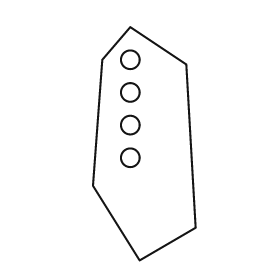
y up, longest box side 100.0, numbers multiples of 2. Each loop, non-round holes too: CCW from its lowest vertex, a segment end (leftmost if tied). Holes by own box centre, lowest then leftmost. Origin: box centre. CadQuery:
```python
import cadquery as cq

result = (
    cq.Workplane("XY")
    .moveTo(-2.0, -50.0)
    .lineTo(22.0, -36.0)
    .lineTo(18.0, 34.0)
    .lineTo(-6.0, 50.0)
    .lineTo(-18.0, 36.0)
    .lineTo(-22.0, -18.0)
    .close()
    .moveTo(-6.0, -6.0)
    .circle(4.0)
    .moveTo(-6.0, 8.0)
    .circle(4.0)
    .moveTo(-6.0, 22.0)
    .circle(4.0)
    .moveTo(-6.0, 36.0)
    .circle(4.0)
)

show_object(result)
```